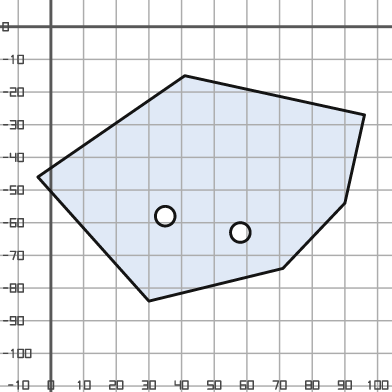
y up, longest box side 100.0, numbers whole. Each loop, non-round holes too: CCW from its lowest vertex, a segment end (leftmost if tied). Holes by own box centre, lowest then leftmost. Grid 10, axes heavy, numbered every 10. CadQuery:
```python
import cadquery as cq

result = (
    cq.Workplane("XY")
    .moveTo(30.0, -84.0)
    .lineTo(71.0, -74.0)
    .lineTo(90.0, -54.0)
    .lineTo(96.0, -27.0)
    .lineTo(41.0, -15.0)
    .lineTo(-4.0, -46.0)
    .close()
    .moveTo(58.0, -63.0)
    .circle(3.0)
    .moveTo(35.0, -58.0)
    .circle(3.0)
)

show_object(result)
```